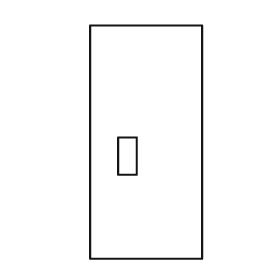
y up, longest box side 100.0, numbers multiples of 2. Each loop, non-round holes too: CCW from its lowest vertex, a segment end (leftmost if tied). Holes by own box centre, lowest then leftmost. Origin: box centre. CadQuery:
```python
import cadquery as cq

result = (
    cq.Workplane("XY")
    .moveTo(-24.0, -50.0)
    .lineTo(24.0, -50.0)
    .lineTo(24.0, 50.0)
    .lineTo(-24.0, 50.0)
    .close()
    .moveTo(-12.0, -14.0)
    .lineTo(-4.0, -14.0)
    .lineTo(-4.0, 2.0)
    .lineTo(-12.0, 2.0)
    .close()
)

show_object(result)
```